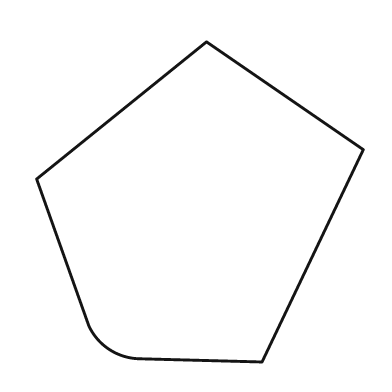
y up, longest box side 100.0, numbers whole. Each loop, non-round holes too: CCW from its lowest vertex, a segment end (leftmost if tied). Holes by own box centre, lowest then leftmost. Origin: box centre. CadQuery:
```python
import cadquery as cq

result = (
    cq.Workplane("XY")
    .moveTo(19.0, -49.0)
    .lineTo(50.0, 16.0)
    .lineTo(2.0, 49.0)
    .lineTo(-50.0, 7.0)
    .lineTo(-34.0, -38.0)
    .threePointArc((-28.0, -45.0), (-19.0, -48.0))
    .close()
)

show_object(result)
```